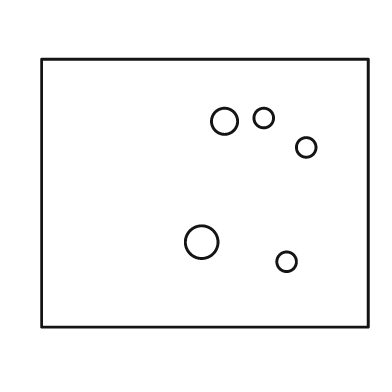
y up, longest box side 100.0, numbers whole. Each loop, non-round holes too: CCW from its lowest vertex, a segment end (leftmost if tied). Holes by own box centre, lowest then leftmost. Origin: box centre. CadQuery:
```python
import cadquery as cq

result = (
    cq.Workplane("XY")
    .moveTo(-50.0, -41.0)
    .lineTo(50.0, -41.0)
    .lineTo(50.0, 41.0)
    .lineTo(-50.0, 41.0)
    .close()
    .moveTo(25.0, -21.0)
    .circle(3.0)
    .moveTo(-1.0, -15.0)
    .circle(5.0)
    .moveTo(31.0, 14.0)
    .circle(3.0)
    .moveTo(6.0, 22.0)
    .circle(4.0)
    .moveTo(18.0, 23.0)
    .circle(3.0)
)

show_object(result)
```